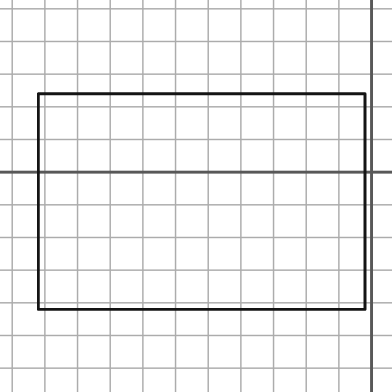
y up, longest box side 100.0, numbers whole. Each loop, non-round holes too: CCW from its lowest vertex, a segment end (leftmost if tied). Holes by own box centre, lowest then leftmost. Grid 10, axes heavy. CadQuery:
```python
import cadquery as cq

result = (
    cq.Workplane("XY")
    .moveTo(-102.0, -42.0)
    .lineTo(-2.0, -42.0)
    .lineTo(-2.0, 24.0)
    .lineTo(-102.0, 24.0)
    .close()
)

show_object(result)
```